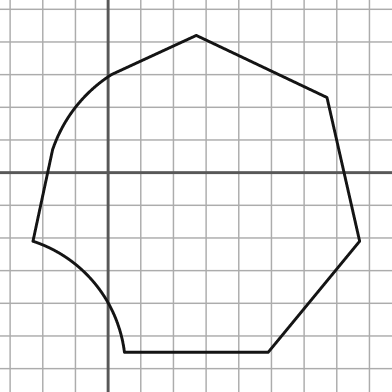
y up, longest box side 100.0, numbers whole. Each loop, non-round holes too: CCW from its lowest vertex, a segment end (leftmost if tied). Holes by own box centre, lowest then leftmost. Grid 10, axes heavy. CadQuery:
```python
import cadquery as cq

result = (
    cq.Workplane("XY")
    .moveTo(5.0, -55.0)
    .lineTo(49.0, -55.0)
    .lineTo(77.0, -21.0)
    .lineTo(67.0, 23.0)
    .lineTo(27.0, 42.0)
    .lineTo(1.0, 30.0)
    .threePointArc((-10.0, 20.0), (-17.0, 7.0))
    .lineTo(-23.0, -21.0)
    .threePointArc((-4.0, -34.0), (5.0, -55.0))
    .close()
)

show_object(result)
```